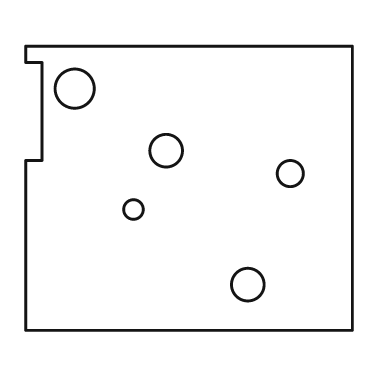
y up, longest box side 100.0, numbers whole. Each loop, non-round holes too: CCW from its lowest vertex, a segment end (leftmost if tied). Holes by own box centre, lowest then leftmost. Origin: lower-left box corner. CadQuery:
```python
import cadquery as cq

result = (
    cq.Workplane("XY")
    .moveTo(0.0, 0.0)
    .lineTo(100.0, 0.0)
    .lineTo(100.0, 87.0)
    .lineTo(0.0, 87.0)
    .lineTo(0.0, 82.0)
    .lineTo(5.0, 82.0)
    .lineTo(5.0, 52.0)
    .lineTo(0.0, 52.0)
    .close()
    .moveTo(68.0, 14.0)
    .circle(5.0)
    .moveTo(33.0, 37.0)
    .circle(3.0)
    .moveTo(81.0, 48.0)
    .circle(4.0)
    .moveTo(43.0, 55.0)
    .circle(5.0)
    .moveTo(15.0, 74.0)
    .circle(6.0)
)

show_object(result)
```